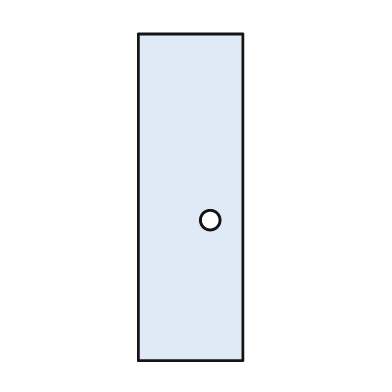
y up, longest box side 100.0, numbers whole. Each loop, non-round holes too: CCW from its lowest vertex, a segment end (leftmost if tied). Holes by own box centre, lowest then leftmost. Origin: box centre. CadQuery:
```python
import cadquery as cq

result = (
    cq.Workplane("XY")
    .moveTo(-16.0, -50.0)
    .lineTo(16.0, -50.0)
    .lineTo(16.0, 50.0)
    .lineTo(-16.0, 50.0)
    .close()
    .moveTo(6.0, -7.0)
    .circle(3.0)
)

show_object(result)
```